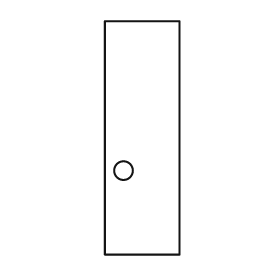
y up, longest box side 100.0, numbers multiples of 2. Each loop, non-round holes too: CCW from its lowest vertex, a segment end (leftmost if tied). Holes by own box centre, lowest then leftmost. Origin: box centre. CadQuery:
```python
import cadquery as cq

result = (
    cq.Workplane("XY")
    .moveTo(-16.0, -50.0)
    .lineTo(16.0, -50.0)
    .lineTo(16.0, 50.0)
    .lineTo(-16.0, 50.0)
    .close()
    .moveTo(-8.0, -14.0)
    .circle(4.0)
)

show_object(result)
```